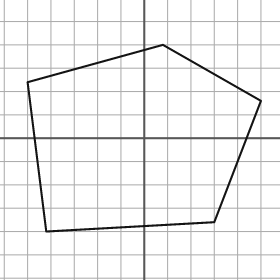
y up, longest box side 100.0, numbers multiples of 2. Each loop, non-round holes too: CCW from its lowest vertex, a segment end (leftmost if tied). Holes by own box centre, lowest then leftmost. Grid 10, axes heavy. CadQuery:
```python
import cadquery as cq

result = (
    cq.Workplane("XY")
    .moveTo(-42.0, -40.0)
    .lineTo(30.0, -36.0)
    .lineTo(50.0, 16.0)
    .lineTo(8.0, 40.0)
    .lineTo(-50.0, 24.0)
    .close()
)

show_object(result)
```